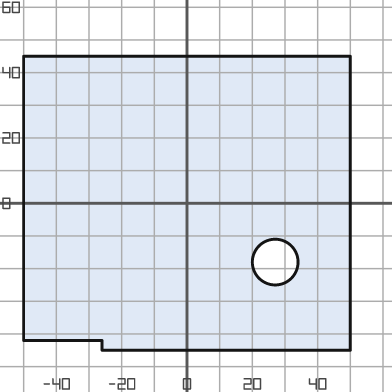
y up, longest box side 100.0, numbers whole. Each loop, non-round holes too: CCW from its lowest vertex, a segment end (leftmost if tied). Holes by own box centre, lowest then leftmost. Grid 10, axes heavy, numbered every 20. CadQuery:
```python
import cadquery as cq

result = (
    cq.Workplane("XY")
    .moveTo(-26.0, -45.0)
    .lineTo(50.0, -45.0)
    .lineTo(50.0, 45.0)
    .lineTo(-50.0, 45.0)
    .lineTo(-50.0, -42.0)
    .lineTo(-26.0, -42.0)
    .close()
    .moveTo(27.0, -18.0)
    .circle(7.0)
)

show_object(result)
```